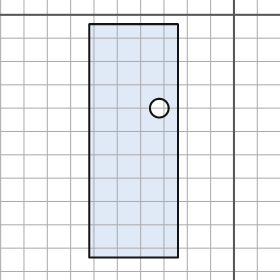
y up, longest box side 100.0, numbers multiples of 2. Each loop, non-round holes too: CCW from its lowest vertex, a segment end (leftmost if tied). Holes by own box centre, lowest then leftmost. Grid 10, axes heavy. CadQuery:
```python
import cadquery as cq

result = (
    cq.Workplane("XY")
    .moveTo(-62.0, -104.0)
    .lineTo(-24.0, -104.0)
    .lineTo(-24.0, -4.0)
    .lineTo(-62.0, -4.0)
    .close()
    .moveTo(-32.0, -40.0)
    .circle(4.0)
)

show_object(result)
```